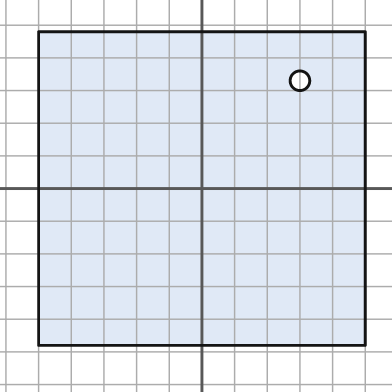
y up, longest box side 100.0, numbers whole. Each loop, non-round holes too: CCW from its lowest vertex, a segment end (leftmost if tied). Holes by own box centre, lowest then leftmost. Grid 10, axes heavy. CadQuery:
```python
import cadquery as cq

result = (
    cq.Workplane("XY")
    .moveTo(-50.0, -48.0)
    .lineTo(50.0, -48.0)
    .lineTo(50.0, 48.0)
    .lineTo(-50.0, 48.0)
    .close()
    .moveTo(30.0, 33.0)
    .circle(3.0)
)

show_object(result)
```